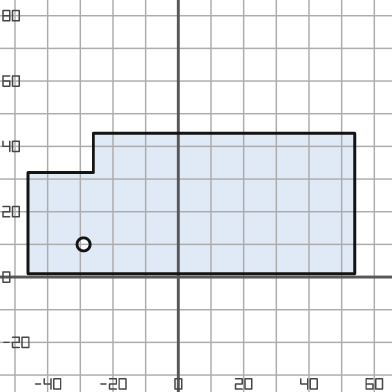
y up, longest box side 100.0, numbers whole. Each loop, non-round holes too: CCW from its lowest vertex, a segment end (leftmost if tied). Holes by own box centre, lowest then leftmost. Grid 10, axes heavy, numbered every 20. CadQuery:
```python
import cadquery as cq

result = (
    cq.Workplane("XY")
    .moveTo(-46.0, 1.0)
    .lineTo(54.0, 1.0)
    .lineTo(54.0, 44.0)
    .lineTo(-26.0, 44.0)
    .lineTo(-26.0, 32.0)
    .lineTo(-46.0, 32.0)
    .close()
    .moveTo(-29.0, 10.0)
    .circle(2.0)
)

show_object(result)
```